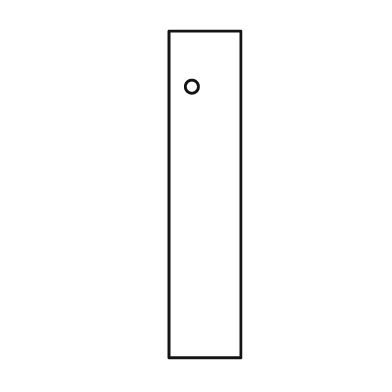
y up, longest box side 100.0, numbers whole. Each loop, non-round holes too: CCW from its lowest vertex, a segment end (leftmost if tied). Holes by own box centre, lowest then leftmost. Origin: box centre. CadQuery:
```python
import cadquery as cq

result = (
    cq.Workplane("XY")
    .moveTo(-11.0, -50.0)
    .lineTo(11.0, -50.0)
    .lineTo(11.0, 50.0)
    .lineTo(-11.0, 50.0)
    .close()
    .moveTo(-4.0, 33.0)
    .circle(2.0)
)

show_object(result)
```